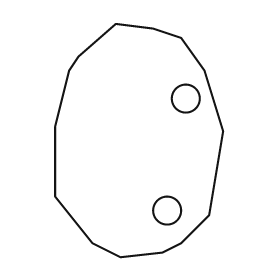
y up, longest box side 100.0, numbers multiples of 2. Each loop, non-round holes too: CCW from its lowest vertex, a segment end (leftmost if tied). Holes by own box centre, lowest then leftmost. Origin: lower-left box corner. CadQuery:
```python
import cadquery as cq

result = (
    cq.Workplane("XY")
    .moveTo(28.0, 0.0)
    .lineTo(46.0, 2.0)
    .lineTo(54.0, 6.0)
    .lineTo(66.0, 18.0)
    .lineTo(72.0, 54.0)
    .lineTo(64.0, 80.0)
    .lineTo(54.0, 94.0)
    .lineTo(42.0, 98.0)
    .lineTo(26.0, 100.0)
    .lineTo(10.0, 86.0)
    .lineTo(6.0, 80.0)
    .lineTo(0.0, 56.0)
    .lineTo(0.0, 26.0)
    .lineTo(16.0, 6.0)
    .close()
    .moveTo(48.0, 20.0)
    .circle(6.0)
    .moveTo(56.0, 68.0)
    .circle(6.0)
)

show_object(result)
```